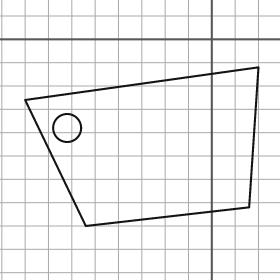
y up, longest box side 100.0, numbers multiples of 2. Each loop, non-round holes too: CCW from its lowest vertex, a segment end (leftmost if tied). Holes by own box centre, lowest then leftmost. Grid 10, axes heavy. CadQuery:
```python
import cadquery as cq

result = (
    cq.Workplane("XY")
    .moveTo(-54.0, -80.0)
    .lineTo(16.0, -72.0)
    .lineTo(20.0, -12.0)
    .lineTo(-80.0, -26.0)
    .close()
    .moveTo(-62.0, -38.0)
    .circle(6.0)
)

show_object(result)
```